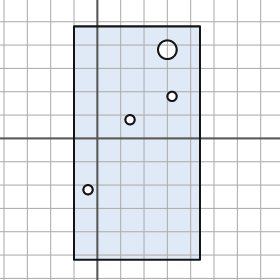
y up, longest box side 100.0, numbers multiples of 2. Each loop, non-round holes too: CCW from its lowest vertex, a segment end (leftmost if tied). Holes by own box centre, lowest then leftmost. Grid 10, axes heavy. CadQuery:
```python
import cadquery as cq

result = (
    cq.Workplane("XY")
    .moveTo(-10.0, -52.0)
    .lineTo(44.0, -52.0)
    .lineTo(44.0, 48.0)
    .lineTo(-10.0, 48.0)
    .close()
    .moveTo(-4.0, -22.0)
    .circle(2.0)
    .moveTo(14.0, 8.0)
    .circle(2.0)
    .moveTo(32.0, 18.0)
    .circle(2.0)
    .moveTo(30.0, 38.0)
    .circle(4.0)
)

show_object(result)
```